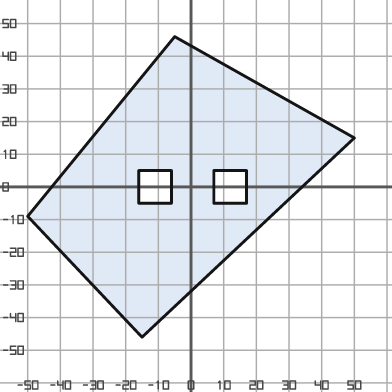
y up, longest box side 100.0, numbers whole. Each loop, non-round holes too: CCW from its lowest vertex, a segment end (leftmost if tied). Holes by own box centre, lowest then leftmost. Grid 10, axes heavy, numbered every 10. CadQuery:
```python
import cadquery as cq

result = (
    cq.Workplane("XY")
    .moveTo(-15.0, -46.0)
    .lineTo(50.0, 15.0)
    .lineTo(-5.0, 46.0)
    .lineTo(-50.0, -9.0)
    .close()
    .moveTo(-16.0, -5.0)
    .lineTo(-6.0, -5.0)
    .lineTo(-6.0, 5.0)
    .lineTo(-16.0, 5.0)
    .close()
    .moveTo(7.0, -5.0)
    .lineTo(17.0, -5.0)
    .lineTo(17.0, 5.0)
    .lineTo(7.0, 5.0)
    .close()
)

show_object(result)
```